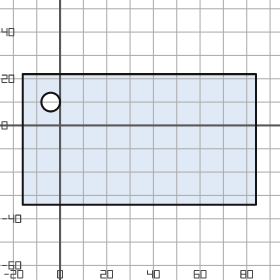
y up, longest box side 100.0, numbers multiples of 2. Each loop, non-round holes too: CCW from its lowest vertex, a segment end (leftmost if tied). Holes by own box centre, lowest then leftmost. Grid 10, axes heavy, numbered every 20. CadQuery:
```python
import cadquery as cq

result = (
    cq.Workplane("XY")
    .moveTo(-16.0, -34.0)
    .lineTo(84.0, -34.0)
    .lineTo(84.0, 22.0)
    .lineTo(-16.0, 22.0)
    .close()
    .moveTo(-4.0, 10.0)
    .circle(4.0)
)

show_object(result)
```